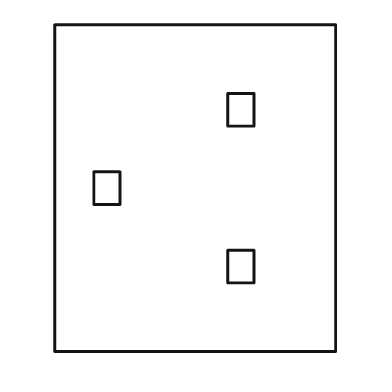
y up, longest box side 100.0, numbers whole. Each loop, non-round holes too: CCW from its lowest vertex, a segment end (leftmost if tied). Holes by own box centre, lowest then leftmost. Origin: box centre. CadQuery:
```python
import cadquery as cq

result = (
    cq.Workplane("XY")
    .moveTo(-43.0, -50.0)
    .lineTo(43.0, -50.0)
    .lineTo(43.0, 50.0)
    .lineTo(-43.0, 50.0)
    .close()
    .moveTo(10.0, -29.0)
    .lineTo(18.0, -29.0)
    .lineTo(18.0, -19.0)
    .lineTo(10.0, -19.0)
    .close()
    .moveTo(-31.0, -5.0)
    .lineTo(-23.0, -5.0)
    .lineTo(-23.0, 5.0)
    .lineTo(-31.0, 5.0)
    .close()
    .moveTo(10.0, 19.0)
    .lineTo(18.0, 19.0)
    .lineTo(18.0, 29.0)
    .lineTo(10.0, 29.0)
    .close()
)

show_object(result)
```